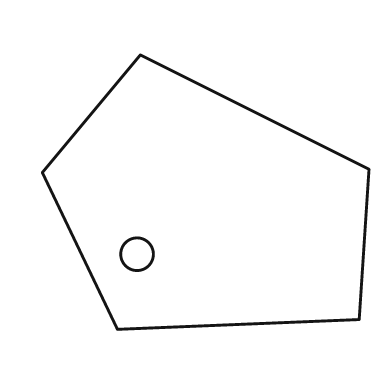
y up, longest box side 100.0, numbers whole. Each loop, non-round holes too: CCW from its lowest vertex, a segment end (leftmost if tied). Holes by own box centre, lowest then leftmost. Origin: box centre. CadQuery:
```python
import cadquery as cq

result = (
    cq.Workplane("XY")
    .moveTo(-27.0, -42.0)
    .lineTo(47.0, -39.0)
    .lineTo(50.0, 7.0)
    .lineTo(-20.0, 42.0)
    .lineTo(-50.0, 6.0)
    .close()
    .moveTo(-21.0, -19.0)
    .circle(5.0)
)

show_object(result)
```